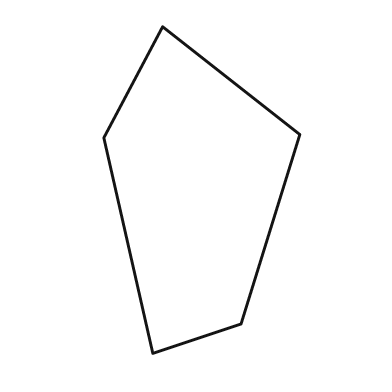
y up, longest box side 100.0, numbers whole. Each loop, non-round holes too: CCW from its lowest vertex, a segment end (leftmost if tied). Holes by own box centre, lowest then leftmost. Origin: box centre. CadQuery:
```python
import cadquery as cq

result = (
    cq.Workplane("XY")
    .moveTo(-15.0, -50.0)
    .lineTo(12.0, -41.0)
    .lineTo(30.0, 17.0)
    .lineTo(-12.0, 50.0)
    .lineTo(-30.0, 16.0)
    .close()
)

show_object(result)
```